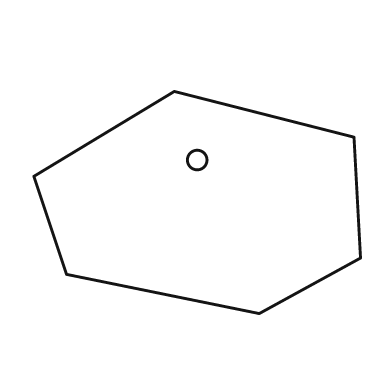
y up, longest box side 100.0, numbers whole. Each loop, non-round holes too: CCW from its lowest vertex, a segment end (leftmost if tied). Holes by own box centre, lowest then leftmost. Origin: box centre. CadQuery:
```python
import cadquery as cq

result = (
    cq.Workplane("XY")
    .moveTo(19.0, -34.0)
    .lineTo(50.0, -17.0)
    .lineTo(48.0, 20.0)
    .lineTo(-7.0, 34.0)
    .lineTo(-50.0, 8.0)
    .lineTo(-40.0, -22.0)
    .close()
    .moveTo(0.0, 13.0)
    .circle(3.0)
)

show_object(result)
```